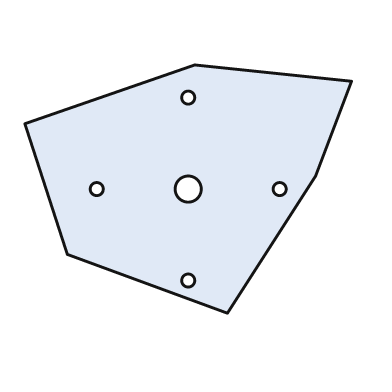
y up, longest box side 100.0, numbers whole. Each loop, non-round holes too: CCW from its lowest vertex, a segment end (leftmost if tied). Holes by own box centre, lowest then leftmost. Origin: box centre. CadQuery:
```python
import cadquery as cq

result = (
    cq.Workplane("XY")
    .moveTo(12.0, -38.0)
    .lineTo(39.0, 4.0)
    .lineTo(50.0, 33.0)
    .lineTo(2.0, 38.0)
    .lineTo(-50.0, 20.0)
    .lineTo(-37.0, -20.0)
    .close()
    .moveTo(0.0, -28.0)
    .circle(2.0)
    .moveTo(-28.0, 0.0)
    .circle(2.0)
    .moveTo(0.0, 0.0)
    .circle(4.0)
    .moveTo(28.0, 0.0)
    .circle(2.0)
    .moveTo(0.0, 28.0)
    .circle(2.0)
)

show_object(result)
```